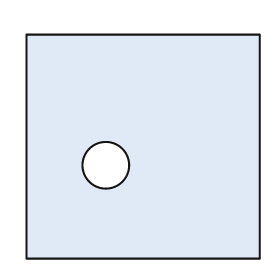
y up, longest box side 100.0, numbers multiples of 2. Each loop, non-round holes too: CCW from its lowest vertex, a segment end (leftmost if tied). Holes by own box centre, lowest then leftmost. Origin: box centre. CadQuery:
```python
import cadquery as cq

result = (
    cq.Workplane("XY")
    .moveTo(-50.0, -48.0)
    .lineTo(50.0, -48.0)
    .lineTo(50.0, 48.0)
    .lineTo(-50.0, 48.0)
    .close()
    .moveTo(-16.0, -8.0)
    .circle(10.0)
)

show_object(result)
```